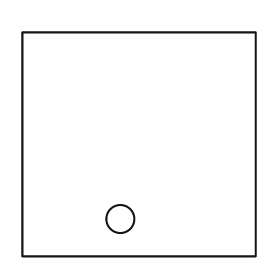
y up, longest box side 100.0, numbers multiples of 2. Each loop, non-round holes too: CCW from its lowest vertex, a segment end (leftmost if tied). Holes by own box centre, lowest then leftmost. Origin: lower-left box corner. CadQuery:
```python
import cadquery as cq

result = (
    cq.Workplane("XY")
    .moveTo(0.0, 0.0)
    .lineTo(100.0, 0.0)
    .lineTo(100.0, 96.0)
    .lineTo(0.0, 96.0)
    .close()
    .moveTo(42.0, 16.0)
    .circle(6.0)
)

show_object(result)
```